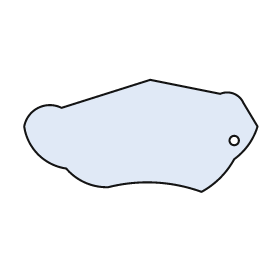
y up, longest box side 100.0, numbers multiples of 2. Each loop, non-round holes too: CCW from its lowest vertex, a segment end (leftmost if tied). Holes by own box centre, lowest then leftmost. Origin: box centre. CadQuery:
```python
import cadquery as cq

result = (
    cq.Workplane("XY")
    .moveTo(26.0, -24.0)
    .threePointArc((34.0, -18.0), (40.0, -10.0))
    .threePointArc((46.0, -4.0), (50.0, 4.0))
    .lineTo(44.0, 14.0)
    .threePointArc((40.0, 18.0), (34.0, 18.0))
    .lineTo(4.0, 24.0)
    .lineTo(-34.0, 12.0)
    .threePointArc((-44.0, 12.0), (-50.0, 4.0))
    .threePointArc((-44.0, -8.0), (-32.0, -14.0))
    .threePointArc((-24.0, -20.0), (-14.0, -22.0))
    .threePointArc((6.0, -20.0), (26.0, -24.0))
    .close()
    .moveTo(40.0, -2.0)
    .circle(2.0)
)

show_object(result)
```